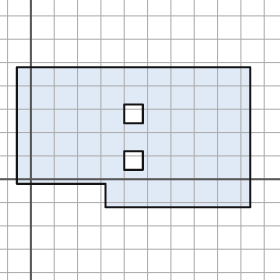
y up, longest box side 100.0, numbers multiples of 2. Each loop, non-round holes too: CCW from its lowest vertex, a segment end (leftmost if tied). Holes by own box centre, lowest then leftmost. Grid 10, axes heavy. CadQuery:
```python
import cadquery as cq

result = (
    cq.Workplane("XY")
    .moveTo(32.0, -12.0)
    .lineTo(94.0, -12.0)
    .lineTo(94.0, 48.0)
    .lineTo(-6.0, 48.0)
    .lineTo(-6.0, -2.0)
    .lineTo(32.0, -2.0)
    .close()
    .moveTo(40.0, 4.0)
    .lineTo(48.0, 4.0)
    .lineTo(48.0, 12.0)
    .lineTo(40.0, 12.0)
    .close()
    .moveTo(40.0, 24.0)
    .lineTo(48.0, 24.0)
    .lineTo(48.0, 32.0)
    .lineTo(40.0, 32.0)
    .close()
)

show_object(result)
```